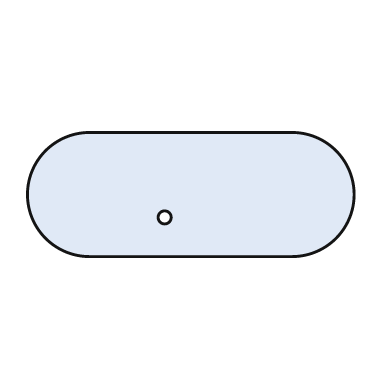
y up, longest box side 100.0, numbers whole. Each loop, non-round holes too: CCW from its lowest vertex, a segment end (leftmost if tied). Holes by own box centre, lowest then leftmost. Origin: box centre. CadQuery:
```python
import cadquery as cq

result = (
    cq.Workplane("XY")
    .moveTo(-31.0, -19.0)
    .lineTo(31.0, -19.0)
    .threePointArc((50.0, 0.0), (31.0, 19.0))
    .lineTo(-31.0, 19.0)
    .threePointArc((-50.0, 0.0), (-31.0, -19.0))
    .close()
    .moveTo(-8.0, -7.0)
    .circle(2.0)
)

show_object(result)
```